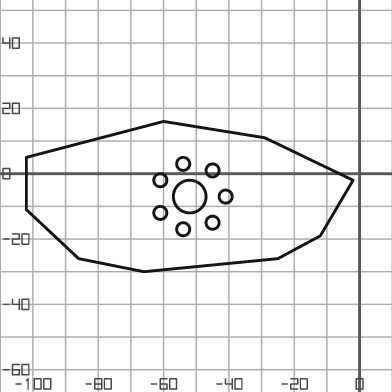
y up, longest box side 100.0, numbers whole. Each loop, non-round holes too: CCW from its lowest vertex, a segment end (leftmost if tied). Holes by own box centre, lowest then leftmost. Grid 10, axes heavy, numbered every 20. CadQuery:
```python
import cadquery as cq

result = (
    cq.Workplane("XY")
    .moveTo(-66.0, -30.0)
    .lineTo(-25.0, -26.0)
    .lineTo(-12.0, -19.0)
    .lineTo(-2.0, -2.0)
    .lineTo(-29.0, 11.0)
    .lineTo(-60.0, 16.0)
    .lineTo(-102.0, 5.0)
    .lineTo(-102.0, -11.0)
    .lineTo(-86.0, -26.0)
    .close()
    .moveTo(-54.0, -17.0)
    .circle(2.0)
    .moveTo(-45.0, -15.0)
    .circle(2.0)
    .moveTo(-61.0, -12.0)
    .circle(2.0)
    .moveTo(-52.0, -7.0)
    .circle(5.0)
    .moveTo(-41.0, -7.0)
    .circle(2.0)
    .moveTo(-61.0, -2.0)
    .circle(2.0)
    .moveTo(-45.0, 1.0)
    .circle(2.0)
    .moveTo(-54.0, 3.0)
    .circle(2.0)
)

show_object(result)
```